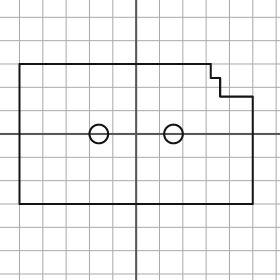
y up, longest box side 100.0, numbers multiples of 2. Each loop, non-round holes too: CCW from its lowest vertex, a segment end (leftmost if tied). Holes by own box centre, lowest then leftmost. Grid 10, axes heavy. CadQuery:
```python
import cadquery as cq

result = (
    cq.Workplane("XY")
    .moveTo(-50.0, -30.0)
    .lineTo(50.0, -30.0)
    .lineTo(50.0, 16.0)
    .lineTo(36.0, 16.0)
    .lineTo(36.0, 24.0)
    .lineTo(32.0, 24.0)
    .lineTo(32.0, 30.0)
    .lineTo(-50.0, 30.0)
    .close()
    .moveTo(-16.0, 0.0)
    .circle(4.0)
    .moveTo(16.0, 0.0)
    .circle(4.0)
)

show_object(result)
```